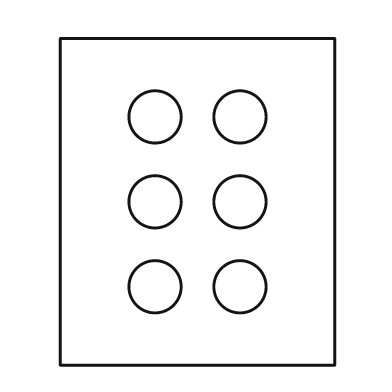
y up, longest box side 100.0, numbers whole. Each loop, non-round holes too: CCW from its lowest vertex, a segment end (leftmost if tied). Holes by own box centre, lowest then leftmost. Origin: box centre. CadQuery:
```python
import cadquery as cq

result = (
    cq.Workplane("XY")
    .moveTo(-42.0, -50.0)
    .lineTo(42.0, -50.0)
    .lineTo(42.0, 50.0)
    .lineTo(-42.0, 50.0)
    .close()
    .moveTo(-13.0, -26.0)
    .circle(8.0)
    .moveTo(13.0, -26.0)
    .circle(8.0)
    .moveTo(-13.0, 0.0)
    .circle(8.0)
    .moveTo(13.0, 0.0)
    .circle(8.0)
    .moveTo(-13.0, 26.0)
    .circle(8.0)
    .moveTo(13.0, 26.0)
    .circle(8.0)
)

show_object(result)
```